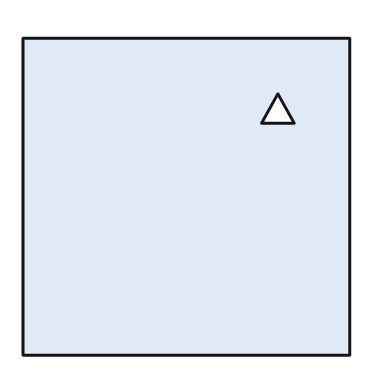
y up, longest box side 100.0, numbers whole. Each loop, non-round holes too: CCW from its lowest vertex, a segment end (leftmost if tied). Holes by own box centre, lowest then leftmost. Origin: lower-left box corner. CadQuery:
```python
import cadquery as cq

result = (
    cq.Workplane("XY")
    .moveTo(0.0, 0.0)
    .lineTo(100.0, 0.0)
    .lineTo(100.0, 97.0)
    .lineTo(0.0, 97.0)
    .close()
    .moveTo(73.0, 71.0)
    .lineTo(83.0, 71.0)
    .lineTo(78.0, 80.0)
    .close()
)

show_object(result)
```